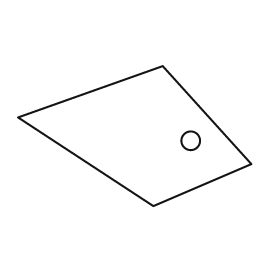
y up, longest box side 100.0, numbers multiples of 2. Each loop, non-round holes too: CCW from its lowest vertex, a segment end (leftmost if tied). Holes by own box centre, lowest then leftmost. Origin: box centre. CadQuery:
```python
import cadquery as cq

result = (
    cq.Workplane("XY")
    .moveTo(8.0, -30.0)
    .lineTo(50.0, -12.0)
    .lineTo(12.0, 30.0)
    .lineTo(-50.0, 8.0)
    .close()
    .moveTo(24.0, -2.0)
    .circle(4.0)
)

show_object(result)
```